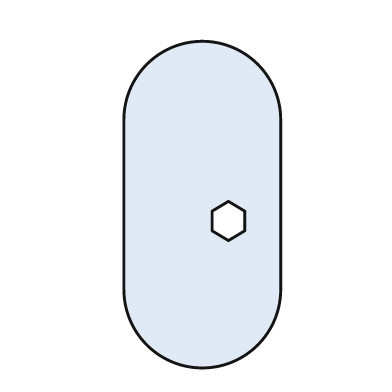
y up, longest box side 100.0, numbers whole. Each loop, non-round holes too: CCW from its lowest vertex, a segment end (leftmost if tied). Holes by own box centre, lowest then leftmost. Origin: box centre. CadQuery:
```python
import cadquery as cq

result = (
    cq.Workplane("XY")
    .moveTo(-24.0, -26.0)
    .threePointArc((0.0, -50.0), (24.0, -26.0))
    .lineTo(24.0, 26.0)
    .threePointArc((0.0, 50.0), (-24.0, 26.0))
    .close()
    .moveTo(8.0, -11.0)
    .lineTo(13.0, -8.0)
    .lineTo(13.0, -2.0)
    .lineTo(8.0, 1.0)
    .lineTo(3.0, -2.0)
    .lineTo(3.0, -8.0)
    .close()
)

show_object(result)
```